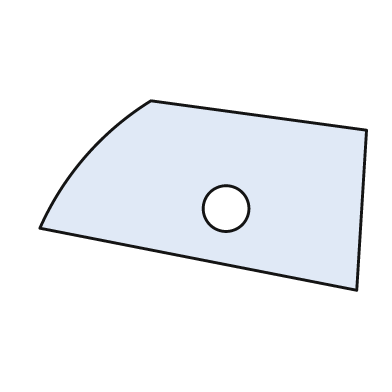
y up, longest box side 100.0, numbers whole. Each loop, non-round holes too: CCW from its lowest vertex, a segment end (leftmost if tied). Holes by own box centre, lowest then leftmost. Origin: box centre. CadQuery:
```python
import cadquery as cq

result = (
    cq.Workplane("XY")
    .moveTo(47.0, -29.0)
    .lineTo(50.0, 20.0)
    .lineTo(-16.0, 29.0)
    .threePointArc((-36.0, 12.0), (-50.0, -10.0))
    .close()
    .moveTo(7.0, -4.0)
    .circle(7.0)
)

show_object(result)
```